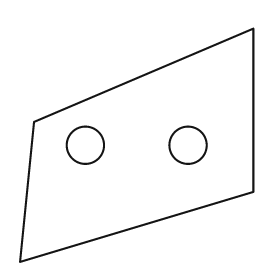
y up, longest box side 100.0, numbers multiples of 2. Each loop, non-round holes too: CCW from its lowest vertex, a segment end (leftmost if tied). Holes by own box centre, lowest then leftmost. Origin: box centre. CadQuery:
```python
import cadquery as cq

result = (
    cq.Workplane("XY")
    .moveTo(-50.0, -50.0)
    .lineTo(50.0, -20.0)
    .lineTo(50.0, 50.0)
    .lineTo(-44.0, 10.0)
    .close()
    .moveTo(-22.0, 0.0)
    .circle(8.0)
    .moveTo(22.0, 0.0)
    .circle(8.0)
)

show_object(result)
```